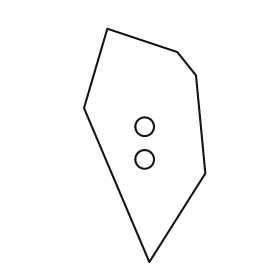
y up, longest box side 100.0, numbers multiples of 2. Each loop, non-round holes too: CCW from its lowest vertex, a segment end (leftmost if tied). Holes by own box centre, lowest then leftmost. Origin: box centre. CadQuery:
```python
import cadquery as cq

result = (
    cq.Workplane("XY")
    .moveTo(2.0, -50.0)
    .lineTo(26.0, -12.0)
    .lineTo(22.0, 30.0)
    .lineTo(14.0, 40.0)
    .lineTo(-16.0, 50.0)
    .lineTo(-26.0, 16.0)
    .close()
    .moveTo(0.0, -6.0)
    .circle(4.0)
    .moveTo(0.0, 8.0)
    .circle(4.0)
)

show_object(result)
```